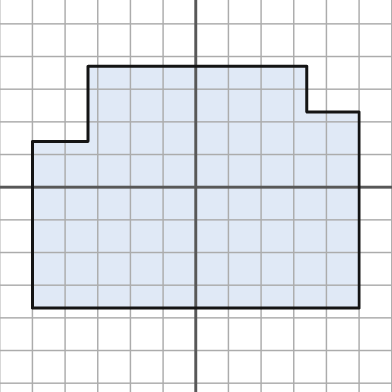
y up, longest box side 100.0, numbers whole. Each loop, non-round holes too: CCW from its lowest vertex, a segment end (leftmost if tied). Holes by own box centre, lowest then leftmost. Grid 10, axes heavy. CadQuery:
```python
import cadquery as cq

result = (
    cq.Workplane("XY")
    .moveTo(-50.0, -37.0)
    .lineTo(50.0, -37.0)
    .lineTo(50.0, 23.0)
    .lineTo(34.0, 23.0)
    .lineTo(34.0, 37.0)
    .lineTo(-33.0, 37.0)
    .lineTo(-33.0, 14.0)
    .lineTo(-50.0, 14.0)
    .close()
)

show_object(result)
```